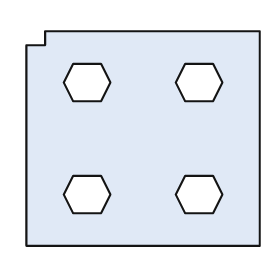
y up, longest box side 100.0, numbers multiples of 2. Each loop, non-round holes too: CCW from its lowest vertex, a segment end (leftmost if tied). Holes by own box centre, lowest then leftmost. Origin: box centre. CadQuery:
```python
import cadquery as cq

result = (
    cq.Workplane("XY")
    .moveTo(-50.0, -46.0)
    .lineTo(50.0, -46.0)
    .lineTo(50.0, 46.0)
    .lineTo(-42.0, 46.0)
    .lineTo(-42.0, 40.0)
    .lineTo(-50.0, 40.0)
    .close()
    .moveTo(-30.0, -32.0)
    .lineTo(-18.0, -32.0)
    .lineTo(-14.0, -24.0)
    .lineTo(-18.0, -16.0)
    .lineTo(-30.0, -16.0)
    .lineTo(-34.0, -24.0)
    .close()
    .moveTo(18.0, -32.0)
    .lineTo(30.0, -32.0)
    .lineTo(34.0, -24.0)
    .lineTo(30.0, -16.0)
    .lineTo(18.0, -16.0)
    .lineTo(14.0, -24.0)
    .close()
    .moveTo(-30.0, 16.0)
    .lineTo(-18.0, 16.0)
    .lineTo(-14.0, 24.0)
    .lineTo(-18.0, 32.0)
    .lineTo(-30.0, 32.0)
    .lineTo(-34.0, 24.0)
    .close()
    .moveTo(18.0, 16.0)
    .lineTo(30.0, 16.0)
    .lineTo(34.0, 24.0)
    .lineTo(30.0, 32.0)
    .lineTo(18.0, 32.0)
    .lineTo(14.0, 24.0)
    .close()
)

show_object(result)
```